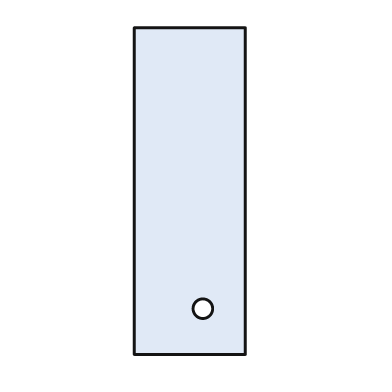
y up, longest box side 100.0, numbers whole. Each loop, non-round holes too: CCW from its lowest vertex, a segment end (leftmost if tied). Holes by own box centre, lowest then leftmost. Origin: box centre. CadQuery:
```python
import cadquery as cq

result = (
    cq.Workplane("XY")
    .moveTo(-17.0, -50.0)
    .lineTo(17.0, -50.0)
    .lineTo(17.0, 50.0)
    .lineTo(-17.0, 50.0)
    .close()
    .moveTo(4.0, -36.0)
    .circle(3.0)
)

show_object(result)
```